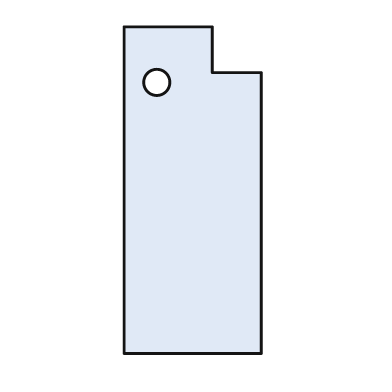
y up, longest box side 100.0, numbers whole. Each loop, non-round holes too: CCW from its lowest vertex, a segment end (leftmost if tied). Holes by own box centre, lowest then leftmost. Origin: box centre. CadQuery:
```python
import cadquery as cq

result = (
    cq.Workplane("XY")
    .moveTo(-21.0, -50.0)
    .lineTo(21.0, -50.0)
    .lineTo(21.0, 36.0)
    .lineTo(6.0, 36.0)
    .lineTo(6.0, 50.0)
    .lineTo(-21.0, 50.0)
    .close()
    .moveTo(-11.0, 33.0)
    .circle(4.0)
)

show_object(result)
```